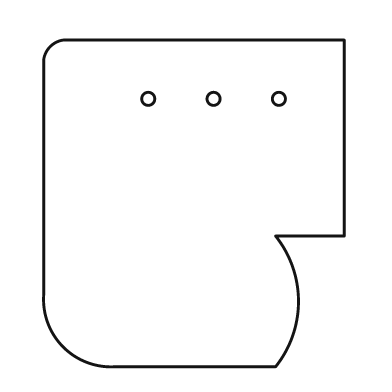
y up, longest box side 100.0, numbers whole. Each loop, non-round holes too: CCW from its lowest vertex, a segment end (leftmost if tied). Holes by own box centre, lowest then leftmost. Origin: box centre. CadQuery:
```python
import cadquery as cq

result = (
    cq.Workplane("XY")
    .moveTo(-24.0, -50.0)
    .lineTo(25.0, -50.0)
    .threePointArc((32.0, -30.0), (25.0, -10.0))
    .lineTo(46.0, -10.0)
    .lineTo(46.0, 50.0)
    .lineTo(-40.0, 50.0)
    .threePointArc((-44.0, 48.0), (-46.0, 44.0))
    .lineTo(-46.0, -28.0)
    .threePointArc((-40.0, -44.0), (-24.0, -50.0))
    .close()
    .moveTo(-14.0, 32.0)
    .circle(2.0)
    .moveTo(6.0, 32.0)
    .circle(2.0)
    .moveTo(26.0, 32.0)
    .circle(2.0)
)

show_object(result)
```